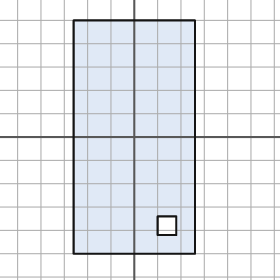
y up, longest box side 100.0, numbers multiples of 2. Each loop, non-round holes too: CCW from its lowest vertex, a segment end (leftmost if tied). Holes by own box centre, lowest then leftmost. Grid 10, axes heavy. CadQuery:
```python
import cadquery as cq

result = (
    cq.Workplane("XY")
    .moveTo(-26.0, -50.0)
    .lineTo(26.0, -50.0)
    .lineTo(26.0, 50.0)
    .lineTo(-26.0, 50.0)
    .close()
    .moveTo(10.0, -42.0)
    .lineTo(18.0, -42.0)
    .lineTo(18.0, -34.0)
    .lineTo(10.0, -34.0)
    .close()
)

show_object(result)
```